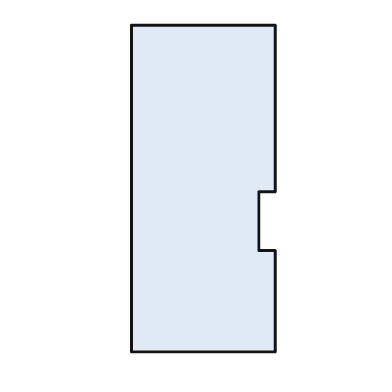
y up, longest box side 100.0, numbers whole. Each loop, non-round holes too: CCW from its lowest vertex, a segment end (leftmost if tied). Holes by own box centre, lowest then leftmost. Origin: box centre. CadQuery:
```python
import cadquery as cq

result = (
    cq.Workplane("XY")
    .moveTo(-22.0, -50.0)
    .lineTo(22.0, -50.0)
    .lineTo(22.0, -19.0)
    .lineTo(17.0, -19.0)
    .lineTo(17.0, -1.0)
    .lineTo(22.0, -1.0)
    .lineTo(22.0, 50.0)
    .lineTo(-22.0, 50.0)
    .close()
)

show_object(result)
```